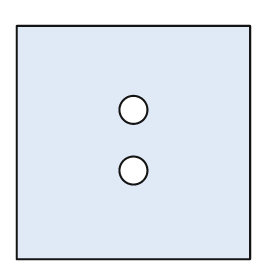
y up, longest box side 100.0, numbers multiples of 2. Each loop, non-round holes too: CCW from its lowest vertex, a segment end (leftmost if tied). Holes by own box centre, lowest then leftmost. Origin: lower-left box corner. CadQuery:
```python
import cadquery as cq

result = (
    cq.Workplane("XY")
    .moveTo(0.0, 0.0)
    .lineTo(100.0, 0.0)
    .lineTo(100.0, 100.0)
    .lineTo(0.0, 100.0)
    .close()
    .moveTo(50.0, 38.0)
    .circle(6.0)
    .moveTo(50.0, 64.0)
    .circle(6.0)
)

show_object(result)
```